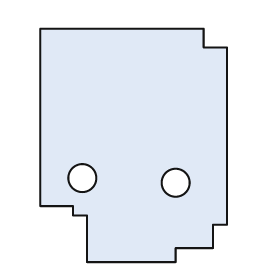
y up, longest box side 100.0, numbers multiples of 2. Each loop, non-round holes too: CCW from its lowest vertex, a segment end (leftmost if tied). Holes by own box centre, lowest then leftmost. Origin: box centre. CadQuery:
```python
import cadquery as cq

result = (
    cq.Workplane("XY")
    .moveTo(-20.0, -50.0)
    .lineTo(18.0, -50.0)
    .lineTo(18.0, -44.0)
    .lineTo(34.0, -44.0)
    .lineTo(34.0, -34.0)
    .lineTo(40.0, -34.0)
    .lineTo(40.0, 42.0)
    .lineTo(30.0, 42.0)
    .lineTo(30.0, 50.0)
    .lineTo(-40.0, 50.0)
    .lineTo(-40.0, -26.0)
    .lineTo(-26.0, -26.0)
    .lineTo(-26.0, -30.0)
    .lineTo(-20.0, -30.0)
    .close()
    .moveTo(18.0, -16.0)
    .circle(6.0)
    .moveTo(-22.0, -14.0)
    .circle(6.0)
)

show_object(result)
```